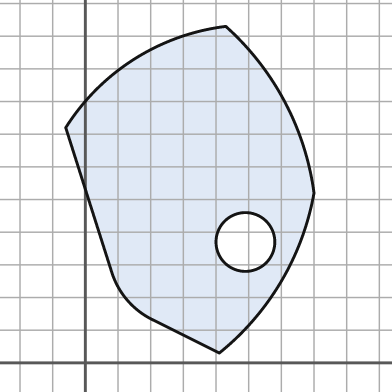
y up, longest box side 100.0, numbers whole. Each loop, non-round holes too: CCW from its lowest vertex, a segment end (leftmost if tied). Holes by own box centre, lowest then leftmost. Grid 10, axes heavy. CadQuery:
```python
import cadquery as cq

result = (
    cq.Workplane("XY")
    .moveTo(41.0, 3.0)
    .threePointArc((60.0, 25.0), (70.0, 52.0))
    .threePointArc((61.0, 80.0), (43.0, 103.0))
    .threePointArc((15.0, 93.0), (-6.0, 72.0))
    .lineTo(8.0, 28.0)
    .threePointArc((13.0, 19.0), (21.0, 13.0))
    .close()
    .moveTo(49.0, 37.0)
    .circle(9.0)
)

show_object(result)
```